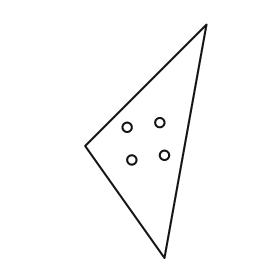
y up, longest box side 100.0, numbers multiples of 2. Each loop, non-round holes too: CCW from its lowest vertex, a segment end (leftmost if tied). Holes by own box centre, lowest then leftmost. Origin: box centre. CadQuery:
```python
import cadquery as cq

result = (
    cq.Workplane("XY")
    .moveTo(8.0, -50.0)
    .lineTo(26.0, 50.0)
    .lineTo(-26.0, -2.0)
    .close()
    .moveTo(-6.0, -8.0)
    .circle(2.0)
    .moveTo(8.0, -6.0)
    .circle(2.0)
    .moveTo(-8.0, 6.0)
    .circle(2.0)
    .moveTo(6.0, 8.0)
    .circle(2.0)
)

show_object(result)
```